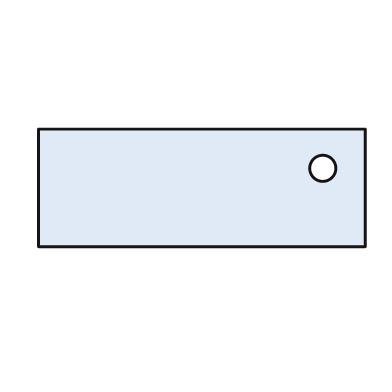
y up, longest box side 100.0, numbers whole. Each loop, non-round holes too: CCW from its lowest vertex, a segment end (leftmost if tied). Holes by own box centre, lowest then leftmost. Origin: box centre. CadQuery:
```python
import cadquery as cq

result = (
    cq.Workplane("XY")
    .moveTo(-50.0, -18.0)
    .lineTo(50.0, -18.0)
    .lineTo(50.0, 18.0)
    .lineTo(-50.0, 18.0)
    .close()
    .moveTo(37.0, 6.0)
    .circle(4.0)
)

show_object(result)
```